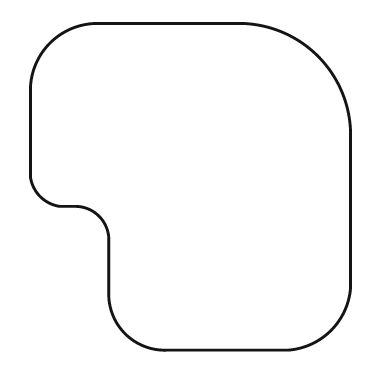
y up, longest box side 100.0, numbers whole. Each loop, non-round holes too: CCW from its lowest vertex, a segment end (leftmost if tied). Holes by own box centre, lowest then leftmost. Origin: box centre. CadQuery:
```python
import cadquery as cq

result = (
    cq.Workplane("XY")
    .moveTo(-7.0, -50.0)
    .lineTo(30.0, -50.0)
    .threePointArc((43.0, -44.0), (49.0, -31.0))
    .lineTo(49.0, 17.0)
    .threePointArc((39.0, 40.0), (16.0, 50.0))
    .lineTo(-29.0, 50.0)
    .threePointArc((-43.0, 44.0), (-49.0, 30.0))
    .lineTo(-49.0, 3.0)
    .threePointArc((-46.0, -3.0), (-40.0, -6.0))
    .lineTo(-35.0, -6.0)
    .threePointArc((-28.0, -9.0), (-25.0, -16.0))
    .lineTo(-25.0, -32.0)
    .threePointArc((-20.0, -45.0), (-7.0, -50.0))
    .close()
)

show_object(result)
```